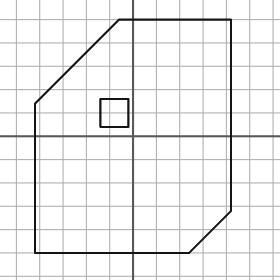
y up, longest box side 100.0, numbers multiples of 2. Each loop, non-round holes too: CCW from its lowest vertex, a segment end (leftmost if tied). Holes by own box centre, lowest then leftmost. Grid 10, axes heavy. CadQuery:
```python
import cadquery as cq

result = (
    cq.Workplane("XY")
    .moveTo(-42.0, -50.0)
    .lineTo(24.0, -50.0)
    .lineTo(42.0, -32.0)
    .lineTo(42.0, 50.0)
    .lineTo(-6.0, 50.0)
    .lineTo(-42.0, 14.0)
    .close()
    .moveTo(-14.0, 4.0)
    .lineTo(-2.0, 4.0)
    .lineTo(-2.0, 16.0)
    .lineTo(-14.0, 16.0)
    .close()
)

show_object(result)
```